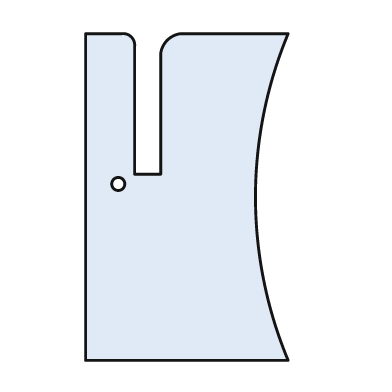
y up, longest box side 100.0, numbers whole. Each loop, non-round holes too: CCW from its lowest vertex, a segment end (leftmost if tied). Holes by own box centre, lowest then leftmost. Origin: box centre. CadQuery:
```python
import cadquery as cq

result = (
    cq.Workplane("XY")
    .moveTo(-31.0, -50.0)
    .lineTo(31.0, -50.0)
    .threePointArc((21.0, 0.0), (31.0, 50.0))
    .lineTo(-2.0, 50.0)
    .threePointArc((-6.0, 48.0), (-8.0, 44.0))
    .lineTo(-8.0, 7.0)
    .lineTo(-16.0, 7.0)
    .lineTo(-16.0, 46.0)
    .threePointArc((-17.0, 49.0), (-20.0, 50.0))
    .lineTo(-31.0, 50.0)
    .close()
    .moveTo(-21.0, 4.0)
    .circle(2.0)
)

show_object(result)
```